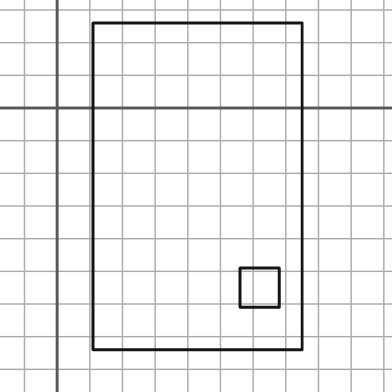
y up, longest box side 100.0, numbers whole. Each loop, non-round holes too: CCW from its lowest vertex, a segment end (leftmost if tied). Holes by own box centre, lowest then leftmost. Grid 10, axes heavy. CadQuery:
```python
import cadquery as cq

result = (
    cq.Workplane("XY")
    .moveTo(11.0, -74.0)
    .lineTo(75.0, -74.0)
    .lineTo(75.0, 26.0)
    .lineTo(11.0, 26.0)
    .close()
    .moveTo(56.0, -61.0)
    .lineTo(68.0, -61.0)
    .lineTo(68.0, -49.0)
    .lineTo(56.0, -49.0)
    .close()
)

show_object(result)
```